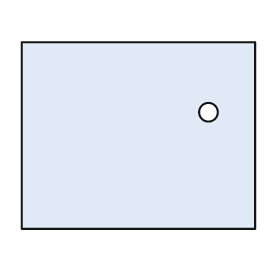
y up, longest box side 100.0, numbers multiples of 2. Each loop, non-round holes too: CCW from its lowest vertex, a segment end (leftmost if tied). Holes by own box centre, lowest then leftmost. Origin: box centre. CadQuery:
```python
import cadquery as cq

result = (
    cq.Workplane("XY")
    .moveTo(-50.0, -40.0)
    .lineTo(50.0, -40.0)
    .lineTo(50.0, 40.0)
    .lineTo(-50.0, 40.0)
    .close()
    .moveTo(30.0, 10.0)
    .circle(4.0)
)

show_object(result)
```